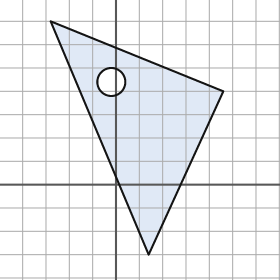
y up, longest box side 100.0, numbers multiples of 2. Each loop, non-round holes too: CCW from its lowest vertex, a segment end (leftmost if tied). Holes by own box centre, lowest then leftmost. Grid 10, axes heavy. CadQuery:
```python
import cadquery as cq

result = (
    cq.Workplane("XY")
    .moveTo(14.0, -30.0)
    .lineTo(46.0, 40.0)
    .lineTo(-28.0, 70.0)
    .close()
    .moveTo(-2.0, 44.0)
    .circle(6.0)
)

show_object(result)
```